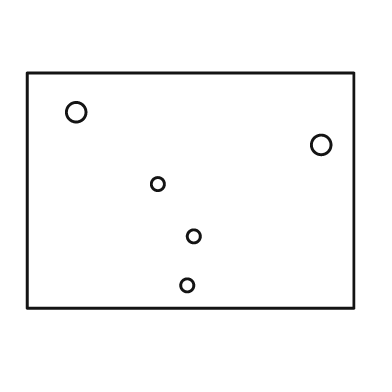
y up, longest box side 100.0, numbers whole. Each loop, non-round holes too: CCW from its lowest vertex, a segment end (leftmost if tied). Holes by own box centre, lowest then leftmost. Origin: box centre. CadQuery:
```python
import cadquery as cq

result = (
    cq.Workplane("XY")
    .moveTo(-50.0, -36.0)
    .lineTo(50.0, -36.0)
    .lineTo(50.0, 36.0)
    .lineTo(-50.0, 36.0)
    .close()
    .moveTo(-1.0, -29.0)
    .circle(2.0)
    .moveTo(1.0, -14.0)
    .circle(2.0)
    .moveTo(-10.0, 2.0)
    .circle(2.0)
    .moveTo(40.0, 14.0)
    .circle(3.0)
    .moveTo(-35.0, 24.0)
    .circle(3.0)
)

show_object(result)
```